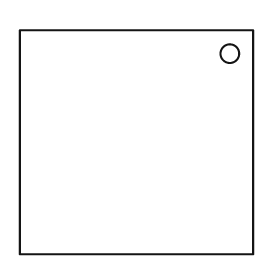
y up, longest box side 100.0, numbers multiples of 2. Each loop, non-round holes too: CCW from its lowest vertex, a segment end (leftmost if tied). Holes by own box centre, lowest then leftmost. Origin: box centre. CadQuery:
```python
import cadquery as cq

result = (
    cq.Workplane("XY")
    .moveTo(-50.0, -48.0)
    .lineTo(50.0, -48.0)
    .lineTo(50.0, 48.0)
    .lineTo(-50.0, 48.0)
    .close()
    .moveTo(40.0, 38.0)
    .circle(4.0)
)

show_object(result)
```